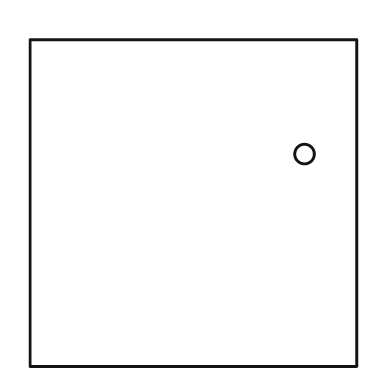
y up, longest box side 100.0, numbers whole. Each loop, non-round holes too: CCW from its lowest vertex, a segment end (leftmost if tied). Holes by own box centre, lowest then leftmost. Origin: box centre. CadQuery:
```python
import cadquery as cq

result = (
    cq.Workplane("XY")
    .moveTo(-50.0, -50.0)
    .lineTo(50.0, -50.0)
    .lineTo(50.0, 50.0)
    .lineTo(-50.0, 50.0)
    .close()
    .moveTo(34.0, 15.0)
    .circle(3.0)
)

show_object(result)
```